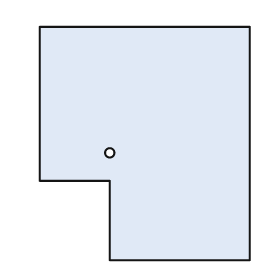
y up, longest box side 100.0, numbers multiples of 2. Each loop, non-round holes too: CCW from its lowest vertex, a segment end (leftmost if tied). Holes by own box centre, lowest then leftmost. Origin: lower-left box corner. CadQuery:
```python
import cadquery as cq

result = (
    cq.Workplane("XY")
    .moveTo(30.0, 0.0)
    .lineTo(90.0, 0.0)
    .lineTo(90.0, 100.0)
    .lineTo(0.0, 100.0)
    .lineTo(0.0, 34.0)
    .lineTo(30.0, 34.0)
    .close()
    .moveTo(30.0, 46.0)
    .circle(2.0)
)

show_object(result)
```